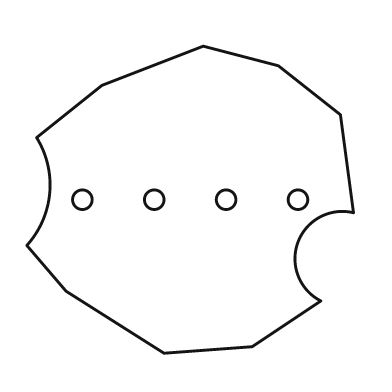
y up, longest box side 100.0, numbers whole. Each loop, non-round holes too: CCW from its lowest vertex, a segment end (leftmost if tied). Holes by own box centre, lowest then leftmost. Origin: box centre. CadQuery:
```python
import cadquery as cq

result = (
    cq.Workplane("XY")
    .moveTo(-8.0, -47.0)
    .lineTo(19.0, -45.0)
    .lineTo(40.0, -31.0)
    .threePointArc((33.0, -13.0), (50.0, -4.0))
    .lineTo(46.0, 26.0)
    .lineTo(27.0, 41.0)
    .lineTo(4.0, 47.0)
    .lineTo(-27.0, 35.0)
    .lineTo(-47.0, 19.0)
    .threePointArc((-43.0, 2.0), (-50.0, -14.0))
    .lineTo(-38.0, -28.0)
    .close()
    .moveTo(-33.0, 0.0)
    .circle(3.0)
    .moveTo(-11.0, 0.0)
    .circle(3.0)
    .moveTo(11.0, 0.0)
    .circle(3.0)
    .moveTo(33.0, 0.0)
    .circle(3.0)
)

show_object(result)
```